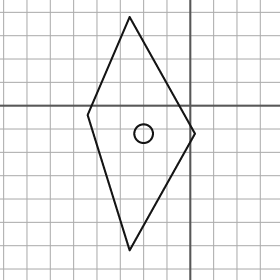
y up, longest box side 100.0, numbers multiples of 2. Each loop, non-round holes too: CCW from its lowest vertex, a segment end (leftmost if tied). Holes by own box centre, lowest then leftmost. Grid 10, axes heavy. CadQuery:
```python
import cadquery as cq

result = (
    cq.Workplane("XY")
    .moveTo(-26.0, -62.0)
    .lineTo(2.0, -12.0)
    .lineTo(-26.0, 38.0)
    .lineTo(-44.0, -4.0)
    .close()
    .moveTo(-20.0, -12.0)
    .circle(4.0)
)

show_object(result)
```